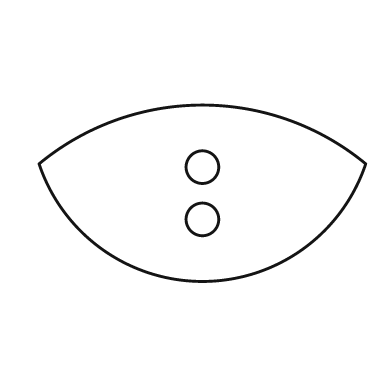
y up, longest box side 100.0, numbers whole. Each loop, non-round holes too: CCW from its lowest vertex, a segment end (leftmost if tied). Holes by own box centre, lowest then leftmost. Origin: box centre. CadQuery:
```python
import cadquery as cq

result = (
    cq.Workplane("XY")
    .moveTo(-50.0, 9.0)
    .threePointArc((0.0, -27.0), (50.0, 9.0))
    .threePointArc((0.0, 27.0), (-50.0, 9.0))
    .close()
    .moveTo(0.0, -8.0)
    .circle(5.0)
    .moveTo(0.0, 8.0)
    .circle(5.0)
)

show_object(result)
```